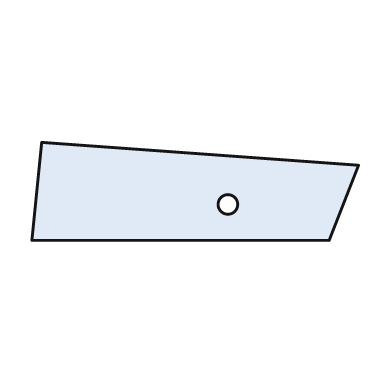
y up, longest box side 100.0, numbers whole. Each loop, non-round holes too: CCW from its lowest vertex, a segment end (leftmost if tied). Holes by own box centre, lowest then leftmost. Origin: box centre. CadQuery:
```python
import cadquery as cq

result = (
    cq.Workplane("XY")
    .moveTo(-50.0, -15.0)
    .lineTo(41.0, -15.0)
    .lineTo(50.0, 8.0)
    .lineTo(-47.0, 15.0)
    .close()
    .moveTo(10.0, -4.0)
    .circle(3.0)
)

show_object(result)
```